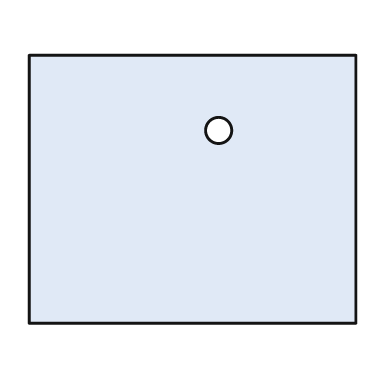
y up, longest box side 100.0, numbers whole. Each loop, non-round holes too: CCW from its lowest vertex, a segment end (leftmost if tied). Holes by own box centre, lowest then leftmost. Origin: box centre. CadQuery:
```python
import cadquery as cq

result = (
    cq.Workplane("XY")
    .moveTo(-50.0, -41.0)
    .lineTo(50.0, -41.0)
    .lineTo(50.0, 41.0)
    .lineTo(-50.0, 41.0)
    .close()
    .moveTo(8.0, 18.0)
    .circle(4.0)
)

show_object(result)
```